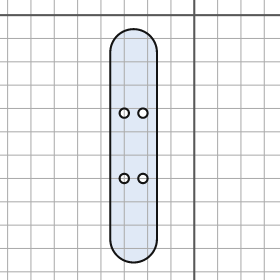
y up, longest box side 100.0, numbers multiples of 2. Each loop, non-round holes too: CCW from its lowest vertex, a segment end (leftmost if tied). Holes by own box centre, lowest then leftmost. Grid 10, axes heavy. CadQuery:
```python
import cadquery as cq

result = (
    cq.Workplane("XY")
    .moveTo(-36.0, -96.0)
    .threePointArc((-26.0, -106.0), (-16.0, -96.0))
    .lineTo(-16.0, -16.0)
    .threePointArc((-26.0, -6.0), (-36.0, -16.0))
    .close()
    .moveTo(-30.0, -70.0)
    .circle(2.0)
    .moveTo(-22.0, -70.0)
    .circle(2.0)
    .moveTo(-30.0, -42.0)
    .circle(2.0)
    .moveTo(-22.0, -42.0)
    .circle(2.0)
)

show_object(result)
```